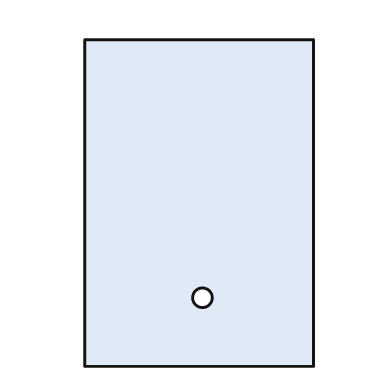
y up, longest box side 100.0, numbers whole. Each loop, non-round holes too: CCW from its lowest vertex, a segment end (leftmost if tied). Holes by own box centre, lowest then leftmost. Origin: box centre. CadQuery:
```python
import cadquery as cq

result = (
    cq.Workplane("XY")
    .moveTo(-35.0, -50.0)
    .lineTo(35.0, -50.0)
    .lineTo(35.0, 50.0)
    .lineTo(-35.0, 50.0)
    .close()
    .moveTo(1.0, -29.0)
    .circle(3.0)
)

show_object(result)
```